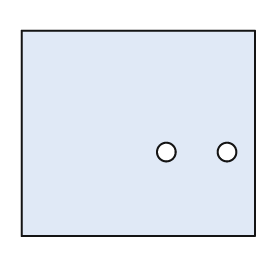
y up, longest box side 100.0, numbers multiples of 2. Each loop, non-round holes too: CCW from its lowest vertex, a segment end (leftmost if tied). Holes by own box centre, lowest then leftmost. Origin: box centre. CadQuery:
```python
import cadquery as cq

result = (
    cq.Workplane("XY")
    .moveTo(-50.0, -44.0)
    .lineTo(50.0, -44.0)
    .lineTo(50.0, 44.0)
    .lineTo(-50.0, 44.0)
    .close()
    .moveTo(12.0, -8.0)
    .circle(4.0)
    .moveTo(38.0, -8.0)
    .circle(4.0)
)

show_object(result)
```